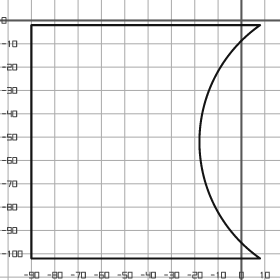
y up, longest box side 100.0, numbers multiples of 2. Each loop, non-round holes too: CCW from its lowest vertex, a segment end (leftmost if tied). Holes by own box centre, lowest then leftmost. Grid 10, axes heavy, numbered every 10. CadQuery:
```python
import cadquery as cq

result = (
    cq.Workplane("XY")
    .moveTo(-90.0, -102.0)
    .lineTo(8.0, -102.0)
    .threePointArc((-18.0, -52.0), (8.0, -2.0))
    .lineTo(-90.0, -2.0)
    .close()
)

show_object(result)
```